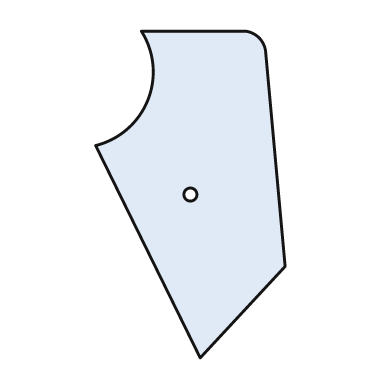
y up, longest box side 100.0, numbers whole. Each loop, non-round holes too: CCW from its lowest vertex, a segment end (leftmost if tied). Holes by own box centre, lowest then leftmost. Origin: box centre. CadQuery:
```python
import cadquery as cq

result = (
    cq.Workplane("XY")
    .moveTo(3.0, -50.0)
    .lineTo(29.0, -22.0)
    .lineTo(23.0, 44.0)
    .threePointArc((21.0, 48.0), (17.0, 50.0))
    .lineTo(-15.0, 50.0)
    .threePointArc((-13.0, 29.0), (-29.0, 15.0))
    .close()
    .moveTo(0.0, 0.0)
    .circle(2.0)
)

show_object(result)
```